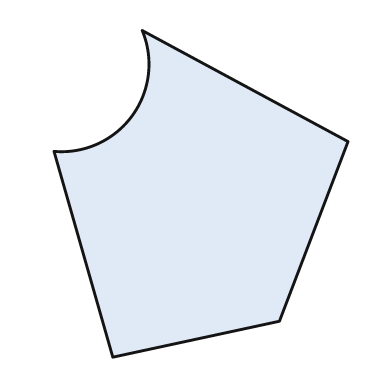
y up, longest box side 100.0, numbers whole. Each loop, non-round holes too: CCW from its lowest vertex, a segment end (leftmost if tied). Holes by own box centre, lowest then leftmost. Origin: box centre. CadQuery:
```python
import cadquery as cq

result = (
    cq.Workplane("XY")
    .moveTo(-27.0, -50.0)
    .lineTo(24.0, -39.0)
    .lineTo(45.0, 16.0)
    .lineTo(-18.0, 50.0)
    .threePointArc((-21.0, 24.0), (-45.0, 13.0))
    .close()
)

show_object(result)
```